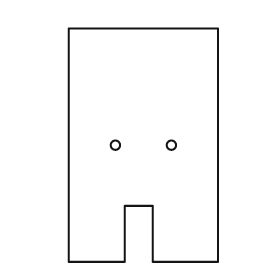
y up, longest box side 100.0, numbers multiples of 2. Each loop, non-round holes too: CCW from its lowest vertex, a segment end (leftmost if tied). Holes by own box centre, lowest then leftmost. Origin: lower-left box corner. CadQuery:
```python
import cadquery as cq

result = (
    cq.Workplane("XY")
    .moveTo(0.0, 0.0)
    .lineTo(24.0, 0.0)
    .lineTo(24.0, 24.0)
    .lineTo(36.0, 24.0)
    .lineTo(36.0, 0.0)
    .lineTo(64.0, 0.0)
    .lineTo(64.0, 100.0)
    .lineTo(0.0, 100.0)
    .close()
    .moveTo(20.0, 50.0)
    .circle(2.0)
    .moveTo(44.0, 50.0)
    .circle(2.0)
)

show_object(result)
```